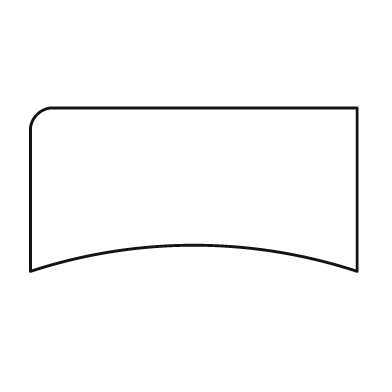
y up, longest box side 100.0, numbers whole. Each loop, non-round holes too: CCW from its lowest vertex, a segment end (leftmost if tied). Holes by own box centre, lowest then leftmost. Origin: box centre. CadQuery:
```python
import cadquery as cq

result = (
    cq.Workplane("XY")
    .moveTo(-50.0, -25.0)
    .threePointArc((0.0, -17.0), (50.0, -25.0))
    .lineTo(50.0, 25.0)
    .lineTo(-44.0, 25.0)
    .threePointArc((-48.0, 23.0), (-50.0, 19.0))
    .close()
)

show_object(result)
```